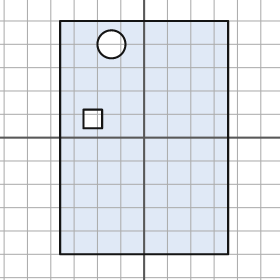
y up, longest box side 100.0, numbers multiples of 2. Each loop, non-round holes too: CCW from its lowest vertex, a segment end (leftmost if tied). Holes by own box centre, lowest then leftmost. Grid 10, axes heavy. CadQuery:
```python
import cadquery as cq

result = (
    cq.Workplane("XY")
    .moveTo(-36.0, -50.0)
    .lineTo(36.0, -50.0)
    .lineTo(36.0, 50.0)
    .lineTo(-36.0, 50.0)
    .close()
    .moveTo(-26.0, 4.0)
    .lineTo(-18.0, 4.0)
    .lineTo(-18.0, 12.0)
    .lineTo(-26.0, 12.0)
    .close()
    .moveTo(-14.0, 40.0)
    .circle(6.0)
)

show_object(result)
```